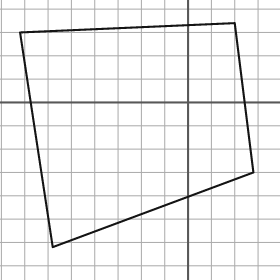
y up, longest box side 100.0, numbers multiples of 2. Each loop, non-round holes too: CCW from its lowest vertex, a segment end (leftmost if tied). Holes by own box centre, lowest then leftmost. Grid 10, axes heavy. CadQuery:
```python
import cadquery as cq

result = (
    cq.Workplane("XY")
    .moveTo(-58.0, -62.0)
    .lineTo(28.0, -30.0)
    .lineTo(20.0, 34.0)
    .lineTo(-72.0, 30.0)
    .close()
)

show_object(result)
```